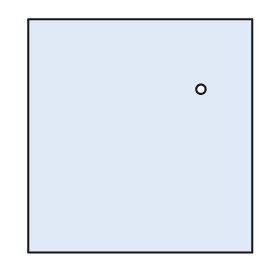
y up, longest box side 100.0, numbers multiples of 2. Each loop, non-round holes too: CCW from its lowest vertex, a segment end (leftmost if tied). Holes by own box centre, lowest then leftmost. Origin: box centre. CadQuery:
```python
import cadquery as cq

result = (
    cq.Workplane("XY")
    .moveTo(-48.0, -50.0)
    .lineTo(48.0, -50.0)
    .lineTo(48.0, 50.0)
    .lineTo(-48.0, 50.0)
    .close()
    .moveTo(26.0, 20.0)
    .circle(2.0)
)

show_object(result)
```